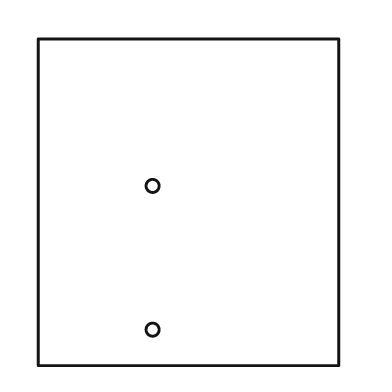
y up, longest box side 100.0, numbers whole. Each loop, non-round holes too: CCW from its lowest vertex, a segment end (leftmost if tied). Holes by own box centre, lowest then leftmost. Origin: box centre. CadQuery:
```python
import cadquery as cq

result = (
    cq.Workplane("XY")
    .moveTo(-46.0, -50.0)
    .lineTo(46.0, -50.0)
    .lineTo(46.0, 50.0)
    .lineTo(-46.0, 50.0)
    .close()
    .moveTo(-11.0, -39.0)
    .circle(2.0)
    .moveTo(-11.0, 5.0)
    .circle(2.0)
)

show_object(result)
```